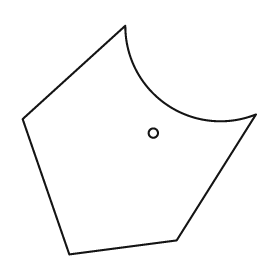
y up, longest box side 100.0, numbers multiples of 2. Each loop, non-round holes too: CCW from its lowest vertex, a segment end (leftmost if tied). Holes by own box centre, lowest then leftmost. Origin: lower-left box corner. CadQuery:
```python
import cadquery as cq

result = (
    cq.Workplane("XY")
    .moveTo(20.0, 0.0)
    .lineTo(66.0, 6.0)
    .lineTo(100.0, 60.0)
    .threePointArc((62.0, 64.0), (44.0, 98.0))
    .lineTo(0.0, 58.0)
    .close()
    .moveTo(56.0, 52.0)
    .circle(2.0)
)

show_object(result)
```